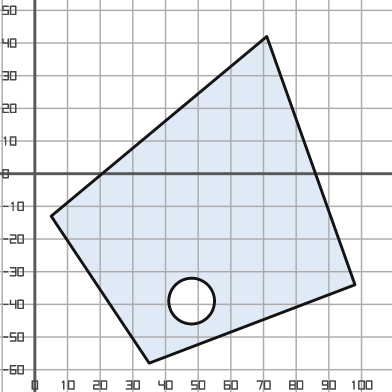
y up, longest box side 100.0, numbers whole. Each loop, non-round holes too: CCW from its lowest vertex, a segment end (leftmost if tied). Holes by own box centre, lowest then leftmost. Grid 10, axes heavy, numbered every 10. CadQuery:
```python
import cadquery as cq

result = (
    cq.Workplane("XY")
    .moveTo(35.0, -58.0)
    .lineTo(98.0, -34.0)
    .lineTo(71.0, 42.0)
    .lineTo(5.0, -13.0)
    .close()
    .moveTo(48.0, -39.0)
    .circle(7.0)
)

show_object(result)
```